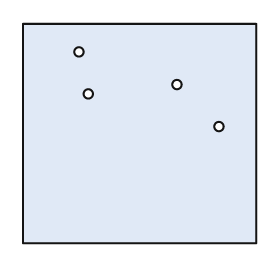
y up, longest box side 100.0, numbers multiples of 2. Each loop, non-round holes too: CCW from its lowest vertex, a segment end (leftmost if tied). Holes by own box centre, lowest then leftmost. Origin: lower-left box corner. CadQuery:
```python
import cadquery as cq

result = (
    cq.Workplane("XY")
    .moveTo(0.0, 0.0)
    .lineTo(100.0, 0.0)
    .lineTo(100.0, 94.0)
    .lineTo(0.0, 94.0)
    .close()
    .moveTo(84.0, 50.0)
    .circle(2.0)
    .moveTo(28.0, 64.0)
    .circle(2.0)
    .moveTo(66.0, 68.0)
    .circle(2.0)
    .moveTo(24.0, 82.0)
    .circle(2.0)
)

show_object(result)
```